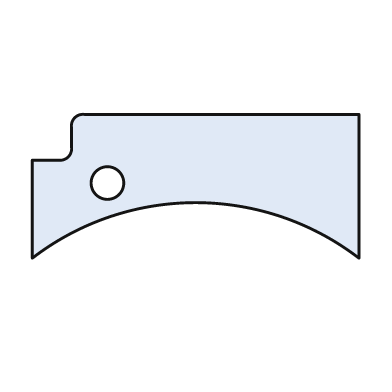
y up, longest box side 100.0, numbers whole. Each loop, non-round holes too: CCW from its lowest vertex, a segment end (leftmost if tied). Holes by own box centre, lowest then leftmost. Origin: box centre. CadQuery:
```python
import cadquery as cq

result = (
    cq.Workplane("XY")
    .moveTo(-50.0, -22.0)
    .threePointArc((0.0, -5.0), (50.0, -22.0))
    .lineTo(50.0, 22.0)
    .lineTo(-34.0, 22.0)
    .threePointArc((-37.0, 21.0), (-38.0, 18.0))
    .lineTo(-38.0, 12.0)
    .threePointArc((-39.0, 9.0), (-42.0, 8.0))
    .lineTo(-50.0, 8.0)
    .close()
    .moveTo(-27.0, 1.0)
    .circle(5.0)
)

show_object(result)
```